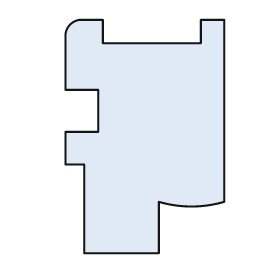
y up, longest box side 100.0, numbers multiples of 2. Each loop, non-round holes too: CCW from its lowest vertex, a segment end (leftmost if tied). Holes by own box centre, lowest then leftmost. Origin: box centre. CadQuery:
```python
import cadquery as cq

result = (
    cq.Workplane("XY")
    .moveTo(-26.0, -50.0)
    .lineTo(6.0, -50.0)
    .lineTo(6.0, -28.0)
    .threePointArc((20.0, -30.0), (34.0, -28.0))
    .lineTo(34.0, 50.0)
    .lineTo(24.0, 50.0)
    .lineTo(24.0, 40.0)
    .lineTo(-18.0, 40.0)
    .lineTo(-18.0, 50.0)
    .lineTo(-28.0, 50.0)
    .threePointArc((-32.0, 48.0), (-34.0, 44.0))
    .lineTo(-34.0, 20.0)
    .lineTo(-20.0, 20.0)
    .lineTo(-20.0, 2.0)
    .lineTo(-34.0, 2.0)
    .lineTo(-34.0, -12.0)
    .lineTo(-26.0, -12.0)
    .close()
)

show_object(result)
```